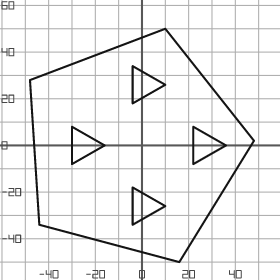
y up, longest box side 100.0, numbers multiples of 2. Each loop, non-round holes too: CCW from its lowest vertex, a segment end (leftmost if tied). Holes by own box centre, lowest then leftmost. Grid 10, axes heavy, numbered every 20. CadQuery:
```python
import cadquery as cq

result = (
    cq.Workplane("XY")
    .moveTo(16.0, -50.0)
    .lineTo(48.0, 2.0)
    .lineTo(10.0, 50.0)
    .lineTo(-48.0, 28.0)
    .lineTo(-44.0, -34.0)
    .close()
    .moveTo(-4.0, -34.0)
    .lineTo(10.0, -26.0)
    .lineTo(-4.0, -18.0)
    .close()
    .moveTo(-30.0, -8.0)
    .lineTo(-16.0, 0.0)
    .lineTo(-30.0, 8.0)
    .close()
    .moveTo(22.0, -8.0)
    .lineTo(36.0, 0.0)
    .lineTo(22.0, 8.0)
    .close()
    .moveTo(-4.0, 18.0)
    .lineTo(10.0, 26.0)
    .lineTo(-4.0, 34.0)
    .close()
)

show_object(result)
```